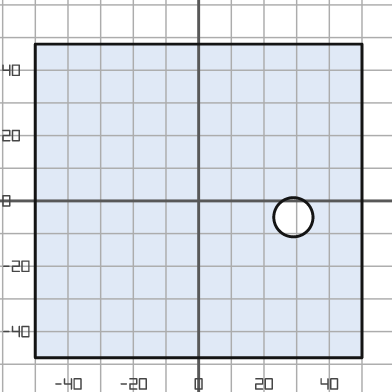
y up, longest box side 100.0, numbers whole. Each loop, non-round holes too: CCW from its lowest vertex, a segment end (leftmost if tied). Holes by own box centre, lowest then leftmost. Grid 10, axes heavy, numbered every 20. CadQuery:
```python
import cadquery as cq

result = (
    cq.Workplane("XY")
    .moveTo(-50.0, -48.0)
    .lineTo(50.0, -48.0)
    .lineTo(50.0, 48.0)
    .lineTo(-50.0, 48.0)
    .close()
    .moveTo(29.0, -5.0)
    .circle(6.0)
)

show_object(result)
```